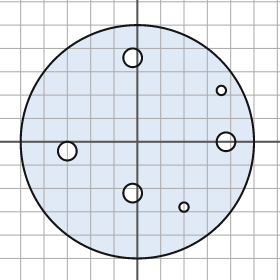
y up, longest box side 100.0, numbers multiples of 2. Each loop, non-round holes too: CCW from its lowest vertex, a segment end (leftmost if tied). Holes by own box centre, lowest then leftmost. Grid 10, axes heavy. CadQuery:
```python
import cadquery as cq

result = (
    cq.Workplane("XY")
    .moveTo(0.0, 0.0)
    .circle(50.0)
    .moveTo(20.0, -28.0)
    .circle(2.0)
    .moveTo(-2.0, -22.0)
    .circle(4.0)
    .moveTo(-30.0, -4.0)
    .circle(4.0)
    .moveTo(38.0, 0.0)
    .circle(4.0)
    .moveTo(36.0, 22.0)
    .circle(2.0)
    .moveTo(-2.0, 36.0)
    .circle(4.0)
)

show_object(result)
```